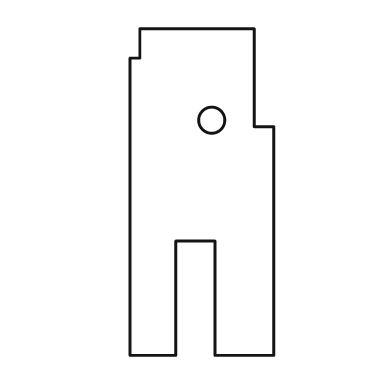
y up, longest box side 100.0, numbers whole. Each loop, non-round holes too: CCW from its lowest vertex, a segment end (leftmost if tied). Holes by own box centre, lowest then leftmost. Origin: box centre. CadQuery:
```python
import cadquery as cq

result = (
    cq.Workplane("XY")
    .moveTo(-22.0, -50.0)
    .lineTo(-8.0, -50.0)
    .lineTo(-8.0, -15.0)
    .lineTo(4.0, -15.0)
    .lineTo(4.0, -50.0)
    .lineTo(22.0, -50.0)
    .lineTo(22.0, 20.0)
    .lineTo(16.0, 20.0)
    .lineTo(16.0, 50.0)
    .lineTo(-19.0, 50.0)
    .lineTo(-19.0, 41.0)
    .lineTo(-22.0, 41.0)
    .close()
    .moveTo(3.0, 22.0)
    .circle(4.0)
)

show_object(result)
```